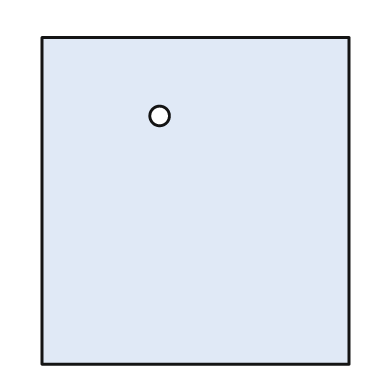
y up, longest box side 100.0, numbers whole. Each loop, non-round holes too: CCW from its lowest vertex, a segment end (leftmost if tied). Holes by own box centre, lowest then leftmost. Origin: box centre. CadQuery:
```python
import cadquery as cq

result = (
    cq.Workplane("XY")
    .moveTo(-47.0, -50.0)
    .lineTo(47.0, -50.0)
    .lineTo(47.0, 50.0)
    .lineTo(-47.0, 50.0)
    .close()
    .moveTo(-11.0, 26.0)
    .circle(3.0)
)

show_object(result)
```